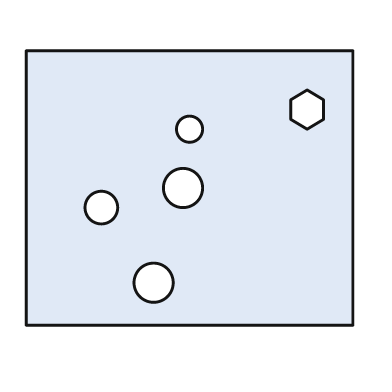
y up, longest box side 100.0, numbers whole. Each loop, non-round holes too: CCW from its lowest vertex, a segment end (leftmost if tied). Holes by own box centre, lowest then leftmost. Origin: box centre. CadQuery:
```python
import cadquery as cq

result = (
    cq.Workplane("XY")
    .moveTo(-50.0, -42.0)
    .lineTo(50.0, -42.0)
    .lineTo(50.0, 42.0)
    .lineTo(-50.0, 42.0)
    .close()
    .moveTo(-11.0, -29.0)
    .circle(6.0)
    .moveTo(-27.0, -6.0)
    .circle(5.0)
    .moveTo(-2.0, 0.0)
    .circle(6.0)
    .moveTo(0.0, 18.0)
    .circle(4.0)
    .moveTo(36.0, 18.0)
    .lineTo(41.0, 21.0)
    .lineTo(41.0, 27.0)
    .lineTo(36.0, 30.0)
    .lineTo(31.0, 27.0)
    .lineTo(31.0, 21.0)
    .close()
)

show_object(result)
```